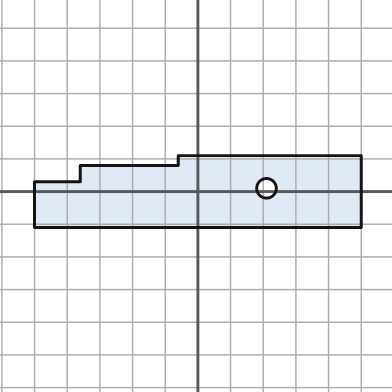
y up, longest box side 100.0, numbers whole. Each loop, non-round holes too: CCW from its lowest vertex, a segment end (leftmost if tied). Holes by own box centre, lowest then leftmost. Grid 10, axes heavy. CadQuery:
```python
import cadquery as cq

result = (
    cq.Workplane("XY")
    .moveTo(-50.0, -11.0)
    .lineTo(50.0, -11.0)
    .lineTo(50.0, 11.0)
    .lineTo(-6.0, 11.0)
    .lineTo(-6.0, 8.0)
    .lineTo(-36.0, 8.0)
    .lineTo(-36.0, 3.0)
    .lineTo(-50.0, 3.0)
    .close()
    .moveTo(21.0, 1.0)
    .circle(3.0)
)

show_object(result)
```